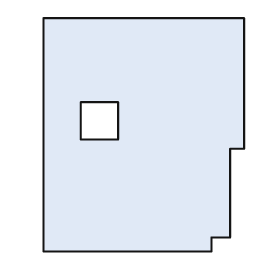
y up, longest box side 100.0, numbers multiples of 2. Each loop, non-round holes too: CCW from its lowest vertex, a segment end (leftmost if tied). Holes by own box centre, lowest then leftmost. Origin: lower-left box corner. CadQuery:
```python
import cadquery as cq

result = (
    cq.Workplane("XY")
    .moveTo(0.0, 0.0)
    .lineTo(72.0, 0.0)
    .lineTo(72.0, 6.0)
    .lineTo(80.0, 6.0)
    .lineTo(80.0, 44.0)
    .lineTo(86.0, 44.0)
    .lineTo(86.0, 100.0)
    .lineTo(0.0, 100.0)
    .close()
    .moveTo(16.0, 48.0)
    .lineTo(32.0, 48.0)
    .lineTo(32.0, 64.0)
    .lineTo(16.0, 64.0)
    .close()
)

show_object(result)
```